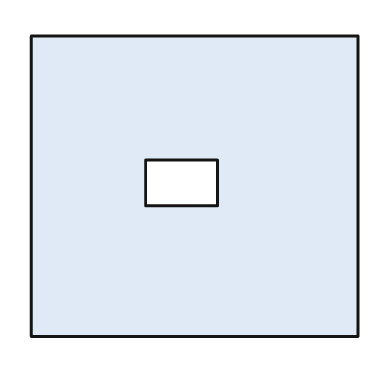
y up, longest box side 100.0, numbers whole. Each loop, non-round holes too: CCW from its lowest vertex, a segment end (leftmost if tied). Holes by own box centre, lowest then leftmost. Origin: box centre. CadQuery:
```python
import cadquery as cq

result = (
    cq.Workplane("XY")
    .moveTo(-50.0, -46.0)
    .lineTo(50.0, -46.0)
    .lineTo(50.0, 46.0)
    .lineTo(-50.0, 46.0)
    .close()
    .moveTo(-15.0, -6.0)
    .lineTo(7.0, -6.0)
    .lineTo(7.0, 8.0)
    .lineTo(-15.0, 8.0)
    .close()
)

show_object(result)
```